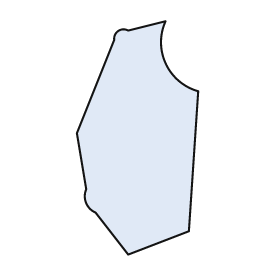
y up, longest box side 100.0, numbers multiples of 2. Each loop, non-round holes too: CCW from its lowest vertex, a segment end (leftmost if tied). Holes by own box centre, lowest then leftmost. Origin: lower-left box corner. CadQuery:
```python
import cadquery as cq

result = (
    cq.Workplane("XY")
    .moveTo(22.0, 0.0)
    .lineTo(48.0, 10.0)
    .lineTo(52.0, 70.0)
    .threePointArc((38.0, 82.0), (38.0, 100.0))
    .lineTo(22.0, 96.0)
    .threePointArc((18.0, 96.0), (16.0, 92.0))
    .lineTo(0.0, 52.0)
    .lineTo(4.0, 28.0)
    .threePointArc((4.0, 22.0), (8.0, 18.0))
    .close()
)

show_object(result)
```